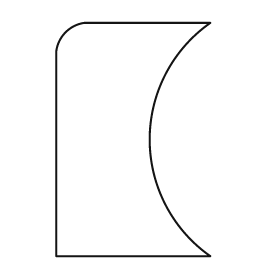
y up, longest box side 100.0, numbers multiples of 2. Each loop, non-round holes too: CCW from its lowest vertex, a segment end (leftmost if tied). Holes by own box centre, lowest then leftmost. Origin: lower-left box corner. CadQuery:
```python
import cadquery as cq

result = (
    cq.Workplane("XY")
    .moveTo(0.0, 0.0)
    .lineTo(66.0, 0.0)
    .threePointArc((40.0, 50.0), (66.0, 100.0))
    .lineTo(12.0, 100.0)
    .threePointArc((4.0, 96.0), (0.0, 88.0))
    .close()
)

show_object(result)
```